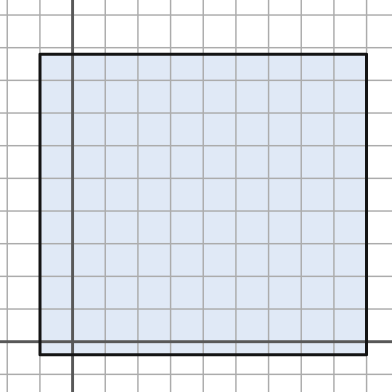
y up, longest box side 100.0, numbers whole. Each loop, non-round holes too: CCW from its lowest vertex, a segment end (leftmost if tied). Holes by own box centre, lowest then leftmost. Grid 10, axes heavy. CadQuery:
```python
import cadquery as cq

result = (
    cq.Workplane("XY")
    .moveTo(-10.0, -4.0)
    .lineTo(90.0, -4.0)
    .lineTo(90.0, 88.0)
    .lineTo(-10.0, 88.0)
    .close()
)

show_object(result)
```